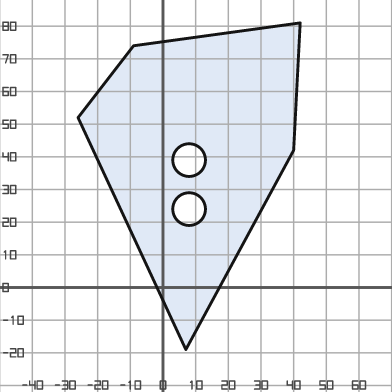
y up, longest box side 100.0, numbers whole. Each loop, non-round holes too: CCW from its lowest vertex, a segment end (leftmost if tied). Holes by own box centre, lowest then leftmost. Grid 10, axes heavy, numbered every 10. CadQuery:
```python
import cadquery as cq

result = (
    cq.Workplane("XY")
    .moveTo(7.0, -19.0)
    .lineTo(40.0, 42.0)
    .lineTo(42.0, 81.0)
    .lineTo(-9.0, 74.0)
    .lineTo(-26.0, 52.0)
    .close()
    .moveTo(8.0, 24.0)
    .circle(5.0)
    .moveTo(8.0, 39.0)
    .circle(5.0)
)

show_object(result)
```